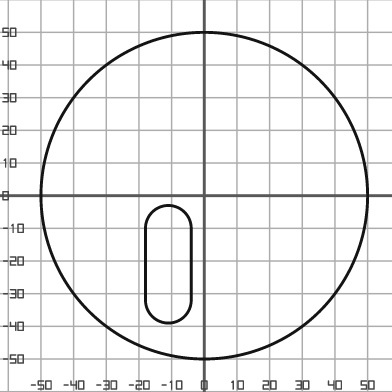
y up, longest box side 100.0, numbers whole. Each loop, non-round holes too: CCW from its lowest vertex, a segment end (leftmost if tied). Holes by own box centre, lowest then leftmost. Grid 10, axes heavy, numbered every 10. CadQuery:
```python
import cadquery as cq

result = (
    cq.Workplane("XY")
    .moveTo(0.0, 0.0)
    .circle(50.0)
    .moveTo(-18.0, -32.0)
    .threePointArc((-11.0, -39.0), (-4.0, -32.0))
    .lineTo(-4.0, -10.0)
    .threePointArc((-11.0, -3.0), (-18.0, -10.0))
    .close()
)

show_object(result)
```